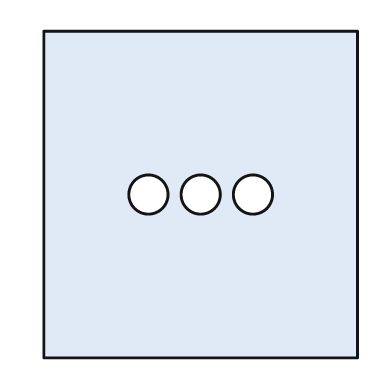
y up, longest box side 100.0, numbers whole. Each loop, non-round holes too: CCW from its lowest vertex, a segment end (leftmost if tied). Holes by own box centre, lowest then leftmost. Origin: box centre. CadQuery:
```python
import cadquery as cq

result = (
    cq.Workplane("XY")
    .moveTo(-48.0, -50.0)
    .lineTo(48.0, -50.0)
    .lineTo(48.0, 50.0)
    .lineTo(-48.0, 50.0)
    .close()
    .moveTo(-16.0, 0.0)
    .circle(6.0)
    .moveTo(0.0, 0.0)
    .circle(6.0)
    .moveTo(16.0, 0.0)
    .circle(6.0)
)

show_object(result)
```